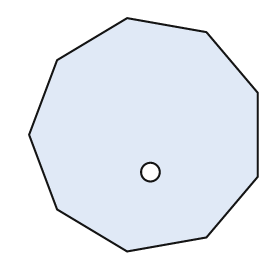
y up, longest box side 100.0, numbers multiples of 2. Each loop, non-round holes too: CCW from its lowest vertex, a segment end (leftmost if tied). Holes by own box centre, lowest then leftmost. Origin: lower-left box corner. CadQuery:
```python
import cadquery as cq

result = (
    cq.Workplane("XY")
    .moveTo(42.0, 0.0)
    .lineTo(76.0, 6.0)
    .lineTo(98.0, 32.0)
    .lineTo(98.0, 68.0)
    .lineTo(76.0, 94.0)
    .lineTo(42.0, 100.0)
    .lineTo(12.0, 82.0)
    .lineTo(0.0, 50.0)
    .lineTo(12.0, 18.0)
    .close()
    .moveTo(52.0, 34.0)
    .circle(4.0)
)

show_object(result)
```